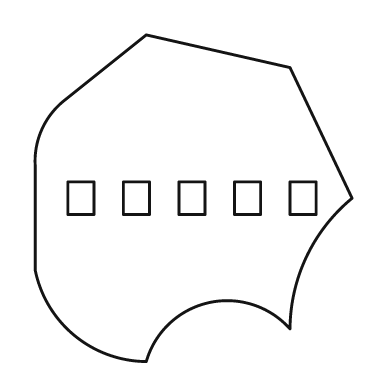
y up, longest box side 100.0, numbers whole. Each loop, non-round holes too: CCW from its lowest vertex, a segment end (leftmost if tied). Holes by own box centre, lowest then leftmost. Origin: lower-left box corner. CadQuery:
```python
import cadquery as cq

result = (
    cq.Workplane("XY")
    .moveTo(34.0, 0.0)
    .threePointArc((53.0, 18.0), (78.0, 10.0))
    .threePointArc((83.0, 32.0), (97.0, 50.0))
    .lineTo(78.0, 90.0)
    .lineTo(34.0, 100.0)
    .lineTo(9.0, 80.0)
    .threePointArc((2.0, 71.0), (0.0, 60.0))
    .lineTo(0.0, 28.0)
    .threePointArc((12.0, 8.0), (34.0, 0.0))
    .close()
    .moveTo(10.0, 45.0)
    .lineTo(18.0, 45.0)
    .lineTo(18.0, 55.0)
    .lineTo(10.0, 55.0)
    .close()
    .moveTo(27.0, 45.0)
    .lineTo(35.0, 45.0)
    .lineTo(35.0, 55.0)
    .lineTo(27.0, 55.0)
    .close()
    .moveTo(44.0, 45.0)
    .lineTo(52.0, 45.0)
    .lineTo(52.0, 55.0)
    .lineTo(44.0, 55.0)
    .close()
    .moveTo(61.0, 45.0)
    .lineTo(69.0, 45.0)
    .lineTo(69.0, 55.0)
    .lineTo(61.0, 55.0)
    .close()
    .moveTo(78.0, 45.0)
    .lineTo(86.0, 45.0)
    .lineTo(86.0, 55.0)
    .lineTo(78.0, 55.0)
    .close()
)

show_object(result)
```